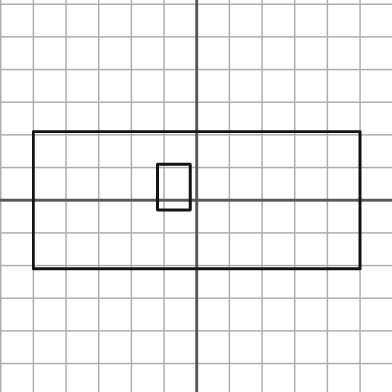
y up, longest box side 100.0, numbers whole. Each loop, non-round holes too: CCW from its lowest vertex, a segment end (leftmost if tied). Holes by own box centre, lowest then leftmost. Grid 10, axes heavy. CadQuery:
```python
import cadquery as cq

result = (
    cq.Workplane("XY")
    .moveTo(-50.0, -21.0)
    .lineTo(50.0, -21.0)
    .lineTo(50.0, 21.0)
    .lineTo(-50.0, 21.0)
    .close()
    .moveTo(-12.0, -3.0)
    .lineTo(-2.0, -3.0)
    .lineTo(-2.0, 11.0)
    .lineTo(-12.0, 11.0)
    .close()
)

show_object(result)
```